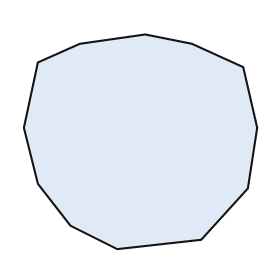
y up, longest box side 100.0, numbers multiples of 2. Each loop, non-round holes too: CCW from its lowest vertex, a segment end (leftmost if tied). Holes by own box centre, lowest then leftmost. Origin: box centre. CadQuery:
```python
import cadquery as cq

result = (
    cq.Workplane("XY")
    .moveTo(-10.0, -46.0)
    .lineTo(26.0, -42.0)
    .lineTo(46.0, -20.0)
    .lineTo(50.0, 6.0)
    .lineTo(44.0, 32.0)
    .lineTo(22.0, 42.0)
    .lineTo(2.0, 46.0)
    .lineTo(-26.0, 42.0)
    .lineTo(-44.0, 34.0)
    .lineTo(-50.0, 6.0)
    .lineTo(-44.0, -18.0)
    .lineTo(-30.0, -36.0)
    .close()
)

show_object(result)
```